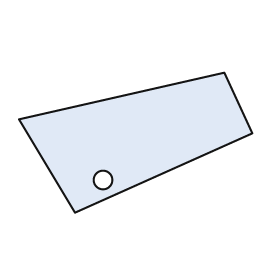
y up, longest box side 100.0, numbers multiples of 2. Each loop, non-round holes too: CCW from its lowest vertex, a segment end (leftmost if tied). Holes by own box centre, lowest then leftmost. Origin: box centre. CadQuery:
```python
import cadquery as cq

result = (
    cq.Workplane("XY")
    .moveTo(-26.0, -30.0)
    .lineTo(50.0, 4.0)
    .lineTo(38.0, 30.0)
    .lineTo(-50.0, 10.0)
    .close()
    .moveTo(-14.0, -16.0)
    .circle(4.0)
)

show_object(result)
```